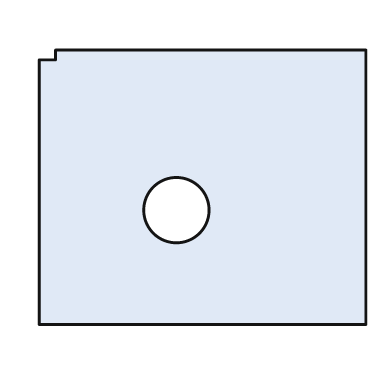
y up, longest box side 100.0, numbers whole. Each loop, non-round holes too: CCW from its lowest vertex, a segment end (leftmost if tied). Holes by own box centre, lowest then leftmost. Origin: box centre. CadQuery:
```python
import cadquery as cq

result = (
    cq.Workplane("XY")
    .moveTo(-50.0, -42.0)
    .lineTo(50.0, -42.0)
    .lineTo(50.0, 42.0)
    .lineTo(-45.0, 42.0)
    .lineTo(-45.0, 39.0)
    .lineTo(-50.0, 39.0)
    .close()
    .moveTo(-8.0, -7.0)
    .circle(10.0)
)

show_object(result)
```